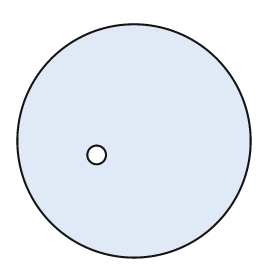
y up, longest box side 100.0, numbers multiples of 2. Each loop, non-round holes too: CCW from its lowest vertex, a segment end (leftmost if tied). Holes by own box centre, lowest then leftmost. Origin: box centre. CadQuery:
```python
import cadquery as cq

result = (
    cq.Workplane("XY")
    .moveTo(0.0, 0.0)
    .circle(50.0)
    .moveTo(-16.0, -6.0)
    .circle(4.0)
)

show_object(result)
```